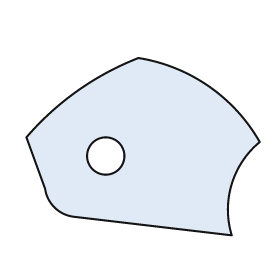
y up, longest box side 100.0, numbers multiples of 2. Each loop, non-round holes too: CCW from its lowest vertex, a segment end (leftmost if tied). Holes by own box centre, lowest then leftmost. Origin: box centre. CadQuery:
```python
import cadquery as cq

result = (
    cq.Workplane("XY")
    .moveTo(38.0, -38.0)
    .threePointArc((38.0, -16.0), (50.0, 2.0))
    .threePointArc((28.0, 26.0), (-2.0, 38.0))
    .threePointArc((-28.0, 24.0), (-50.0, 4.0))
    .lineTo(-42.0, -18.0)
    .threePointArc((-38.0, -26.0), (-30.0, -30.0))
    .close()
    .moveTo(-16.0, -4.0)
    .circle(8.0)
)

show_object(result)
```